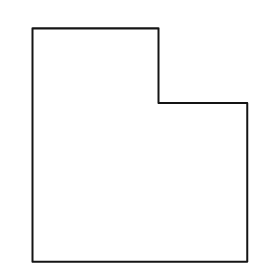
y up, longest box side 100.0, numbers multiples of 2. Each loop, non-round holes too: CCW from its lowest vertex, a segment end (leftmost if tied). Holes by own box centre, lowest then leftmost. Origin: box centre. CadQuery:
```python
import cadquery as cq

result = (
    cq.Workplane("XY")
    .moveTo(-46.0, -50.0)
    .lineTo(46.0, -50.0)
    .lineTo(46.0, 18.0)
    .lineTo(8.0, 18.0)
    .lineTo(8.0, 50.0)
    .lineTo(-46.0, 50.0)
    .close()
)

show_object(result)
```